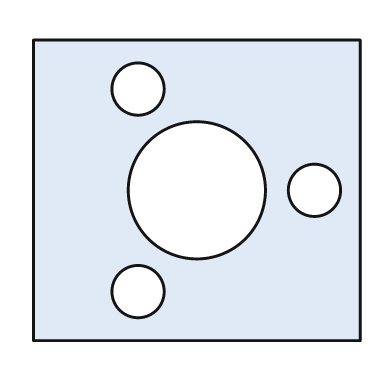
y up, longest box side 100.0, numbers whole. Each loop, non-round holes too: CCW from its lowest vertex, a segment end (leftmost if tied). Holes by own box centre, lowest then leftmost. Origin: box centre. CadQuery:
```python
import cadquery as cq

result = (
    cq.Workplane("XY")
    .moveTo(-50.0, -46.0)
    .lineTo(50.0, -46.0)
    .lineTo(50.0, 46.0)
    .lineTo(-50.0, 46.0)
    .close()
    .moveTo(-18.0, -31.0)
    .circle(8.0)
    .moveTo(0.0, 0.0)
    .circle(21.0)
    .moveTo(36.0, 0.0)
    .circle(8.0)
    .moveTo(-18.0, 31.0)
    .circle(8.0)
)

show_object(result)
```